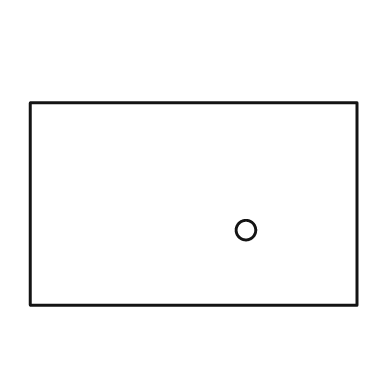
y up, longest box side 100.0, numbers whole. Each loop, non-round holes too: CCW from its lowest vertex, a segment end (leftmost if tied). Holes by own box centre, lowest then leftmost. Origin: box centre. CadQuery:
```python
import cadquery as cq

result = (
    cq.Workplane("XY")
    .moveTo(-50.0, -31.0)
    .lineTo(50.0, -31.0)
    .lineTo(50.0, 31.0)
    .lineTo(-50.0, 31.0)
    .close()
    .moveTo(16.0, -8.0)
    .circle(3.0)
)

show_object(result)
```